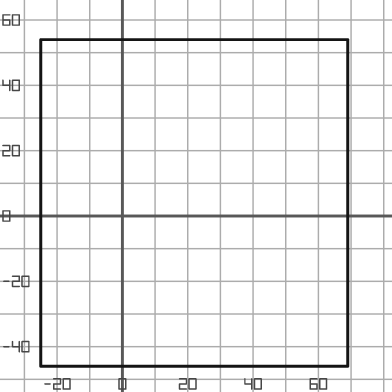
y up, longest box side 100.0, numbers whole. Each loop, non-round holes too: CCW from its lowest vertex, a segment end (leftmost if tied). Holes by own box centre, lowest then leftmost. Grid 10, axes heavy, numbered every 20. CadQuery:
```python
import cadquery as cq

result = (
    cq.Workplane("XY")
    .moveTo(-25.0, -46.0)
    .lineTo(69.0, -46.0)
    .lineTo(69.0, 54.0)
    .lineTo(-25.0, 54.0)
    .close()
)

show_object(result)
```